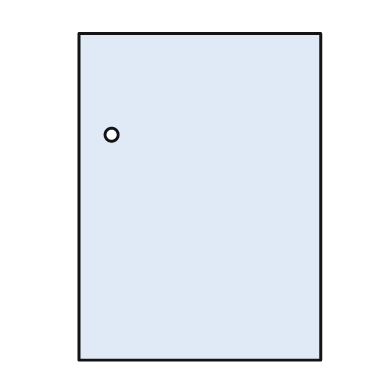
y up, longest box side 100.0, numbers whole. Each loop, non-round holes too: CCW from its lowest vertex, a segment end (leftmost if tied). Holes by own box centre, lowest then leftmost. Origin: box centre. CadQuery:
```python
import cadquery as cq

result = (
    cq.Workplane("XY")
    .moveTo(-37.0, -50.0)
    .lineTo(37.0, -50.0)
    .lineTo(37.0, 50.0)
    .lineTo(-37.0, 50.0)
    .close()
    .moveTo(-27.0, 19.0)
    .circle(2.0)
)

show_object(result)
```